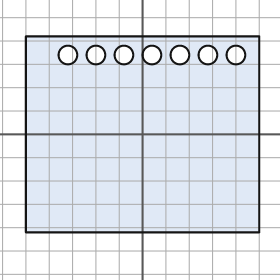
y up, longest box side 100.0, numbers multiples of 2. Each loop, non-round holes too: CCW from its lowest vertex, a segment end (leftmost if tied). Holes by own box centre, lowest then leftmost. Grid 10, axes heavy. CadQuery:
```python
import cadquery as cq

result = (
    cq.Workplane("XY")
    .moveTo(-50.0, -42.0)
    .lineTo(50.0, -42.0)
    .lineTo(50.0, 42.0)
    .lineTo(-50.0, 42.0)
    .close()
    .moveTo(-32.0, 34.0)
    .circle(4.0)
    .moveTo(-20.0, 34.0)
    .circle(4.0)
    .moveTo(-8.0, 34.0)
    .circle(4.0)
    .moveTo(4.0, 34.0)
    .circle(4.0)
    .moveTo(16.0, 34.0)
    .circle(4.0)
    .moveTo(28.0, 34.0)
    .circle(4.0)
    .moveTo(40.0, 34.0)
    .circle(4.0)
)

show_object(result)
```